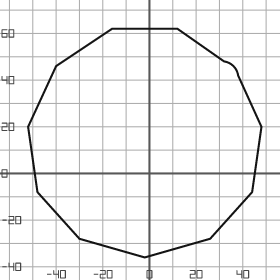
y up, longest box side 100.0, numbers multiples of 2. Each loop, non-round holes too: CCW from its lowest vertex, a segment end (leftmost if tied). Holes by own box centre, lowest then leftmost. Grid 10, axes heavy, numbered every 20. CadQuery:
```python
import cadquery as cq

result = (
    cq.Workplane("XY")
    .moveTo(-2.0, -36.0)
    .lineTo(26.0, -28.0)
    .lineTo(44.0, -8.0)
    .lineTo(48.0, 20.0)
    .lineTo(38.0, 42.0)
    .threePointArc((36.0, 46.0), (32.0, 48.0))
    .lineTo(12.0, 62.0)
    .lineTo(-16.0, 62.0)
    .lineTo(-40.0, 46.0)
    .lineTo(-52.0, 20.0)
    .lineTo(-48.0, -8.0)
    .lineTo(-30.0, -28.0)
    .close()
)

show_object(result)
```